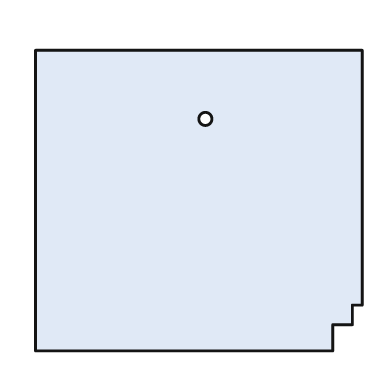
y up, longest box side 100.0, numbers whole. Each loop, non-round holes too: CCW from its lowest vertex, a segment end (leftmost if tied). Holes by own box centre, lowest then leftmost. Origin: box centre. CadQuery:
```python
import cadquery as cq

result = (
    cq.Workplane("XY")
    .moveTo(-50.0, -46.0)
    .lineTo(41.0, -46.0)
    .lineTo(41.0, -38.0)
    .lineTo(47.0, -38.0)
    .lineTo(47.0, -32.0)
    .lineTo(50.0, -32.0)
    .lineTo(50.0, 46.0)
    .lineTo(-50.0, 46.0)
    .close()
    .moveTo(2.0, 25.0)
    .circle(2.0)
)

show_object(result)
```